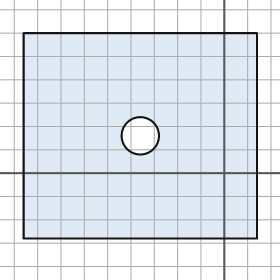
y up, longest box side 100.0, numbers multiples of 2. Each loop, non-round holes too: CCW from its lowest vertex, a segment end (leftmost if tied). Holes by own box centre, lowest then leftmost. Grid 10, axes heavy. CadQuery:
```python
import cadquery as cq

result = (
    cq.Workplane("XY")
    .moveTo(-86.0, -28.0)
    .lineTo(14.0, -28.0)
    .lineTo(14.0, 60.0)
    .lineTo(-86.0, 60.0)
    .close()
    .moveTo(-36.0, 16.0)
    .circle(8.0)
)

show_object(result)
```